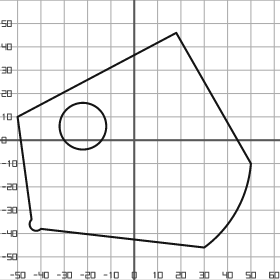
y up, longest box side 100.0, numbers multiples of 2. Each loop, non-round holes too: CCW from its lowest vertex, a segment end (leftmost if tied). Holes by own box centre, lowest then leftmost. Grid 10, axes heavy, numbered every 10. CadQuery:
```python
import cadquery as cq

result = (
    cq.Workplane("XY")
    .moveTo(30.0, -46.0)
    .threePointArc((44.0, -30.0), (50.0, -10.0))
    .lineTo(18.0, 46.0)
    .lineTo(-50.0, 10.0)
    .lineTo(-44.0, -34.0)
    .threePointArc((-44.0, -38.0), (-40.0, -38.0))
    .close()
    .moveTo(-22.0, 6.0)
    .circle(10.0)
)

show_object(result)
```